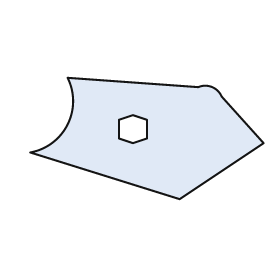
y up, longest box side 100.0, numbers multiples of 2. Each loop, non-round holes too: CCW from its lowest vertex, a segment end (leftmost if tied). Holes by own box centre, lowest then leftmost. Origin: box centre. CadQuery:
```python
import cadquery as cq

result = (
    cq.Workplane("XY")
    .moveTo(14.0, -26.0)
    .lineTo(50.0, -2.0)
    .lineTo(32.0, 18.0)
    .threePointArc((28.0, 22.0), (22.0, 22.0))
    .lineTo(-34.0, 26.0)
    .threePointArc((-34.0, 6.0), (-50.0, -6.0))
    .close()
    .moveTo(-6.0, -2.0)
    .lineTo(0.0, 0.0)
    .lineTo(0.0, 8.0)
    .lineTo(-6.0, 10.0)
    .lineTo(-12.0, 8.0)
    .lineTo(-12.0, 0.0)
    .close()
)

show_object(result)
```